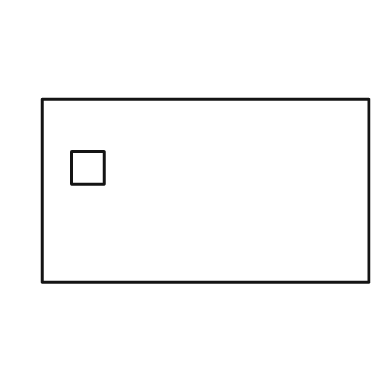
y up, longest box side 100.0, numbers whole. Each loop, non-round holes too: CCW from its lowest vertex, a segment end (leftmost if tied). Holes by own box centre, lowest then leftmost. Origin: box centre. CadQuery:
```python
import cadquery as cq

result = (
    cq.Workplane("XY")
    .moveTo(-50.0, -28.0)
    .lineTo(50.0, -28.0)
    .lineTo(50.0, 28.0)
    .lineTo(-50.0, 28.0)
    .close()
    .moveTo(-41.0, 2.0)
    .lineTo(-31.0, 2.0)
    .lineTo(-31.0, 12.0)
    .lineTo(-41.0, 12.0)
    .close()
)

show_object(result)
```